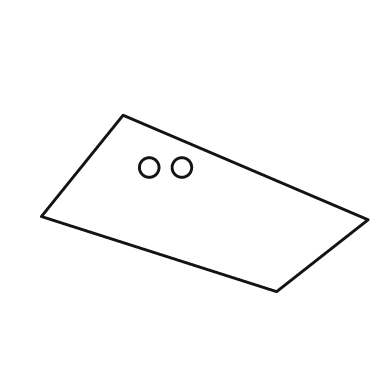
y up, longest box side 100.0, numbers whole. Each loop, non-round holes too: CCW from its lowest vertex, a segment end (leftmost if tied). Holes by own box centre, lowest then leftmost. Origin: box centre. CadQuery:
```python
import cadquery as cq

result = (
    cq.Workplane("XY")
    .moveTo(22.0, -27.0)
    .lineTo(50.0, -5.0)
    .lineTo(-25.0, 27.0)
    .lineTo(-50.0, -4.0)
    .close()
    .moveTo(-17.0, 11.0)
    .circle(3.0)
    .moveTo(-7.0, 11.0)
    .circle(3.0)
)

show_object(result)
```